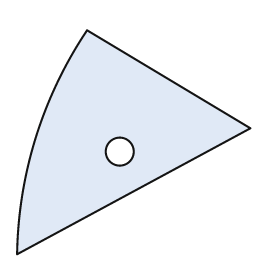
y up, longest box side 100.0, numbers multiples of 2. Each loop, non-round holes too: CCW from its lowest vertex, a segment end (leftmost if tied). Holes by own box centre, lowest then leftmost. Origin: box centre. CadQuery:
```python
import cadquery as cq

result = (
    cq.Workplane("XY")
    .moveTo(-50.0, -48.0)
    .lineTo(50.0, 6.0)
    .lineTo(-20.0, 48.0)
    .threePointArc((-42.0, 2.0), (-50.0, -48.0))
    .close()
    .moveTo(-6.0, -4.0)
    .circle(6.0)
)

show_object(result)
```